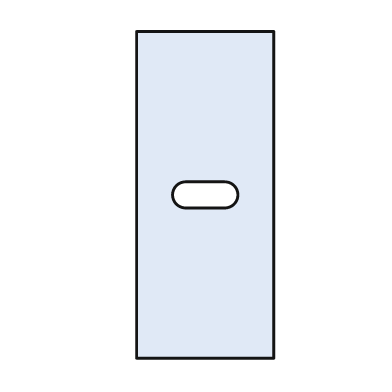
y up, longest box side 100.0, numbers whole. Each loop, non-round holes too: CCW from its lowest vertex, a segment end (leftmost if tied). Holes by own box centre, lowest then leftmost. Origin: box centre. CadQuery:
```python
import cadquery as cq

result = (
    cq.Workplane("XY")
    .moveTo(-21.0, -50.0)
    .lineTo(21.0, -50.0)
    .lineTo(21.0, 50.0)
    .lineTo(-21.0, 50.0)
    .close()
    .moveTo(-6.0, -4.0)
    .lineTo(6.0, -4.0)
    .threePointArc((10.0, 0.0), (6.0, 4.0))
    .lineTo(-6.0, 4.0)
    .threePointArc((-10.0, 0.0), (-6.0, -4.0))
    .close()
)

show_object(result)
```